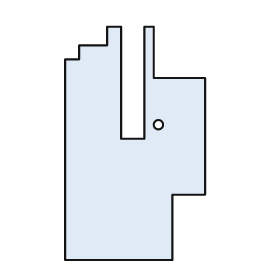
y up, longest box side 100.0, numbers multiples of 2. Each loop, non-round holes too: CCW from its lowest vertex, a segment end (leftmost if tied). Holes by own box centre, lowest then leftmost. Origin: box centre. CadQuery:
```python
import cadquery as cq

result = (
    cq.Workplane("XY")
    .moveTo(-30.0, -50.0)
    .lineTo(16.0, -50.0)
    .lineTo(16.0, -22.0)
    .lineTo(30.0, -22.0)
    .lineTo(30.0, 28.0)
    .lineTo(8.0, 28.0)
    .lineTo(8.0, 50.0)
    .lineTo(4.0, 50.0)
    .lineTo(4.0, 2.0)
    .lineTo(-6.0, 2.0)
    .lineTo(-6.0, 50.0)
    .lineTo(-12.0, 50.0)
    .lineTo(-12.0, 42.0)
    .lineTo(-24.0, 42.0)
    .lineTo(-24.0, 36.0)
    .lineTo(-30.0, 36.0)
    .close()
    .moveTo(10.0, 8.0)
    .circle(2.0)
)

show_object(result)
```